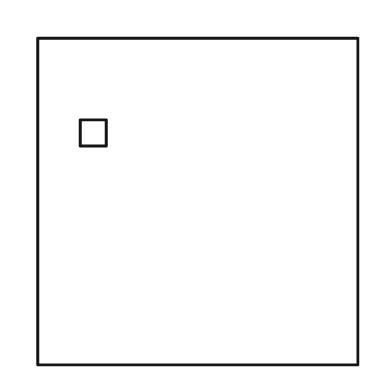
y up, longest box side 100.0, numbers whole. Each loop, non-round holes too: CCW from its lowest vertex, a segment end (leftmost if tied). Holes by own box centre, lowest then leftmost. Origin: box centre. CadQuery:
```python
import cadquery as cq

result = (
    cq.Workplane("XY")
    .moveTo(-49.0, -50.0)
    .lineTo(49.0, -50.0)
    .lineTo(49.0, 50.0)
    .lineTo(-49.0, 50.0)
    .close()
    .moveTo(-36.0, 17.0)
    .lineTo(-28.0, 17.0)
    .lineTo(-28.0, 25.0)
    .lineTo(-36.0, 25.0)
    .close()
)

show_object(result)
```